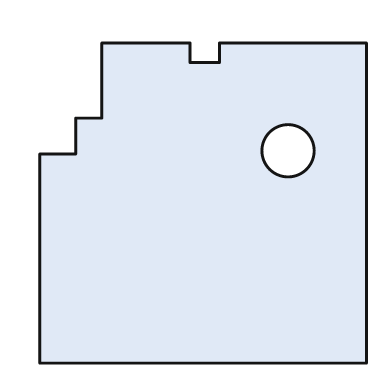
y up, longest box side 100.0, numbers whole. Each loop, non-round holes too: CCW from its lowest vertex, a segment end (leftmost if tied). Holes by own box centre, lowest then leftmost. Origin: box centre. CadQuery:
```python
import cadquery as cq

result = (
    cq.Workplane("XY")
    .moveTo(-50.0, -49.0)
    .lineTo(50.0, -49.0)
    .lineTo(50.0, 49.0)
    .lineTo(5.0, 49.0)
    .lineTo(5.0, 43.0)
    .lineTo(-4.0, 43.0)
    .lineTo(-4.0, 49.0)
    .lineTo(-31.0, 49.0)
    .lineTo(-31.0, 26.0)
    .lineTo(-39.0, 26.0)
    .lineTo(-39.0, 15.0)
    .lineTo(-50.0, 15.0)
    .close()
    .moveTo(26.0, 16.0)
    .circle(8.0)
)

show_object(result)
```